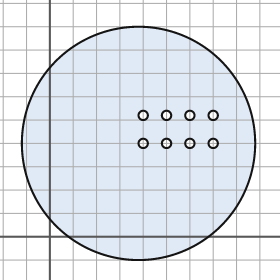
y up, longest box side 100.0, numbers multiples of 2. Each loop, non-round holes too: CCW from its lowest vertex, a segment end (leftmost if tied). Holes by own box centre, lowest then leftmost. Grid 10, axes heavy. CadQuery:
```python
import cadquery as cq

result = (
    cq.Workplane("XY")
    .moveTo(38.0, 40.0)
    .circle(50.0)
    .moveTo(40.0, 40.0)
    .circle(2.0)
    .moveTo(50.0, 40.0)
    .circle(2.0)
    .moveTo(60.0, 40.0)
    .circle(2.0)
    .moveTo(70.0, 40.0)
    .circle(2.0)
    .moveTo(40.0, 52.0)
    .circle(2.0)
    .moveTo(50.0, 52.0)
    .circle(2.0)
    .moveTo(60.0, 52.0)
    .circle(2.0)
    .moveTo(70.0, 52.0)
    .circle(2.0)
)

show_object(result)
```